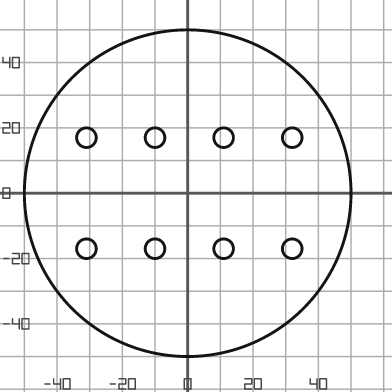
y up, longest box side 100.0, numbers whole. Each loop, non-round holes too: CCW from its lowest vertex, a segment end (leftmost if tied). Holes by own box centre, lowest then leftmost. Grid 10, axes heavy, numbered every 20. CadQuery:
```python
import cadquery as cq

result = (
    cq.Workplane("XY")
    .moveTo(0.0, 0.0)
    .circle(50.0)
    .moveTo(-31.0, -17.0)
    .circle(3.0)
    .moveTo(-10.0, -17.0)
    .circle(3.0)
    .moveTo(11.0, -17.0)
    .circle(3.0)
    .moveTo(32.0, -17.0)
    .circle(3.0)
    .moveTo(-31.0, 17.0)
    .circle(3.0)
    .moveTo(-10.0, 17.0)
    .circle(3.0)
    .moveTo(11.0, 17.0)
    .circle(3.0)
    .moveTo(32.0, 17.0)
    .circle(3.0)
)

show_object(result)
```